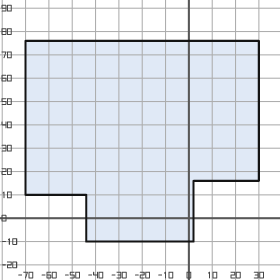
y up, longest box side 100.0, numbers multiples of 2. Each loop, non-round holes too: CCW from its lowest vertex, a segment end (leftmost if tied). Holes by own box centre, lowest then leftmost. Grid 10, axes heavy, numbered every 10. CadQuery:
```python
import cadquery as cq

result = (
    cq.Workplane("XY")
    .moveTo(-44.0, -10.0)
    .lineTo(2.0, -10.0)
    .lineTo(2.0, 16.0)
    .lineTo(30.0, 16.0)
    .lineTo(30.0, 76.0)
    .lineTo(-70.0, 76.0)
    .lineTo(-70.0, 10.0)
    .lineTo(-44.0, 10.0)
    .close()
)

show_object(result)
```